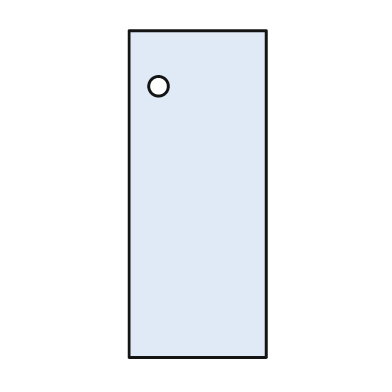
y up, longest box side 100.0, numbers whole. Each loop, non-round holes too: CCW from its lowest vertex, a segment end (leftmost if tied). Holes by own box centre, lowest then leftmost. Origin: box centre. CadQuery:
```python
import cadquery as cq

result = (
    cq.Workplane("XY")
    .moveTo(-21.0, -50.0)
    .lineTo(21.0, -50.0)
    .lineTo(21.0, 50.0)
    .lineTo(-21.0, 50.0)
    .close()
    .moveTo(-12.0, 33.0)
    .circle(3.0)
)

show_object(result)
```